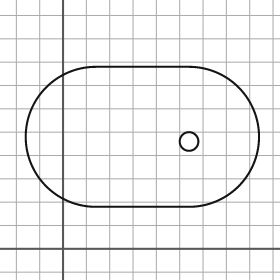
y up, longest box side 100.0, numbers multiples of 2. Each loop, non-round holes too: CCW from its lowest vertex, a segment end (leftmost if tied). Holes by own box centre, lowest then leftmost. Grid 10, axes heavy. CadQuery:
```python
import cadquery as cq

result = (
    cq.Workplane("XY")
    .moveTo(14.0, 18.0)
    .lineTo(54.0, 18.0)
    .threePointArc((84.0, 48.0), (54.0, 78.0))
    .lineTo(14.0, 78.0)
    .threePointArc((-16.0, 48.0), (14.0, 18.0))
    .close()
    .moveTo(54.0, 46.0)
    .circle(4.0)
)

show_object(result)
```